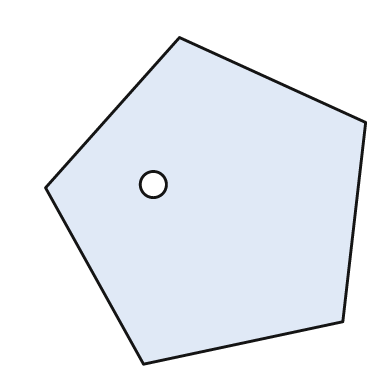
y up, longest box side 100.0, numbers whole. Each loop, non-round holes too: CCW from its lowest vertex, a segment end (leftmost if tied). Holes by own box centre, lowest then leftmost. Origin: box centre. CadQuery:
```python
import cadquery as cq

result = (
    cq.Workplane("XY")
    .moveTo(-19.0, -50.0)
    .lineTo(42.0, -37.0)
    .lineTo(49.0, 24.0)
    .lineTo(-8.0, 50.0)
    .lineTo(-49.0, 4.0)
    .close()
    .moveTo(-16.0, 5.0)
    .circle(4.0)
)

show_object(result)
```